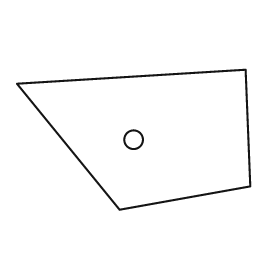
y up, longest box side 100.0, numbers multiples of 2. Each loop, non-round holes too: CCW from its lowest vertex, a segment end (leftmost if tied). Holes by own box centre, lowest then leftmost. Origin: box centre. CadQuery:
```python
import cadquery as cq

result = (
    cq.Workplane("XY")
    .moveTo(-6.0, -30.0)
    .lineTo(50.0, -20.0)
    .lineTo(48.0, 30.0)
    .lineTo(-50.0, 24.0)
    .close()
    .moveTo(0.0, 0.0)
    .circle(4.0)
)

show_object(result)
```